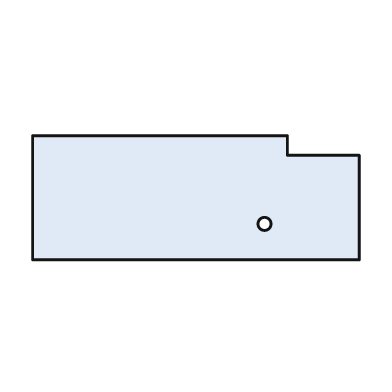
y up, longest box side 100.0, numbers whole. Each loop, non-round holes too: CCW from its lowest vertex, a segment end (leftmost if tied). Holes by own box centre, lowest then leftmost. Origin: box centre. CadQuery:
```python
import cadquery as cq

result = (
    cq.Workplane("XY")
    .moveTo(-50.0, -19.0)
    .lineTo(50.0, -19.0)
    .lineTo(50.0, 13.0)
    .lineTo(28.0, 13.0)
    .lineTo(28.0, 19.0)
    .lineTo(-50.0, 19.0)
    .close()
    .moveTo(21.0, -8.0)
    .circle(2.0)
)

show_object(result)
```